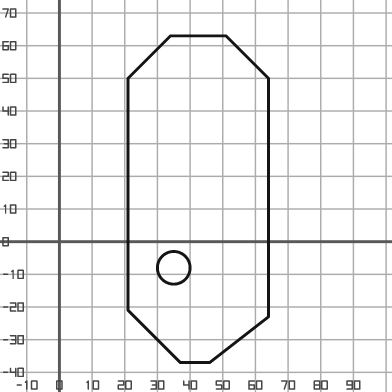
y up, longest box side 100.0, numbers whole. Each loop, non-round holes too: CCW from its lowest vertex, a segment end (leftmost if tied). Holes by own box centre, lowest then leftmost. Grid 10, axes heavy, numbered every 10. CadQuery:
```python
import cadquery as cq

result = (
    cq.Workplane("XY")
    .moveTo(37.0, -37.0)
    .lineTo(46.0, -37.0)
    .lineTo(64.0, -23.0)
    .lineTo(64.0, 50.0)
    .lineTo(51.0, 63.0)
    .lineTo(34.0, 63.0)
    .lineTo(21.0, 50.0)
    .lineTo(21.0, -21.0)
    .close()
    .moveTo(35.0, -8.0)
    .circle(5.0)
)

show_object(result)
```